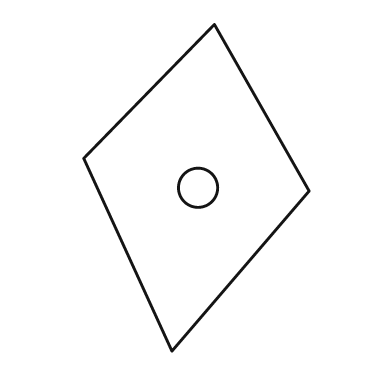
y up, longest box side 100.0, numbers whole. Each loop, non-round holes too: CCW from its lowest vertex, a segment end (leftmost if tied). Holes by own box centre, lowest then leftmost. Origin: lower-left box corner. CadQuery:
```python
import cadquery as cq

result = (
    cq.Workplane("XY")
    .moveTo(27.0, 0.0)
    .lineTo(69.0, 49.0)
    .lineTo(40.0, 100.0)
    .lineTo(0.0, 59.0)
    .close()
    .moveTo(35.0, 50.0)
    .circle(6.0)
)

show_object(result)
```